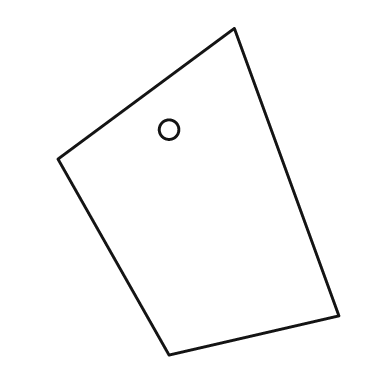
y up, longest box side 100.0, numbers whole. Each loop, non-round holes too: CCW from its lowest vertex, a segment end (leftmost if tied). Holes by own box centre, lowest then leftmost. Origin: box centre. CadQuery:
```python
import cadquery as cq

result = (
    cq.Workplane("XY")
    .moveTo(-9.0, -50.0)
    .lineTo(43.0, -38.0)
    .lineTo(11.0, 50.0)
    .lineTo(-43.0, 10.0)
    .close()
    .moveTo(-9.0, 19.0)
    .circle(3.0)
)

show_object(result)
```